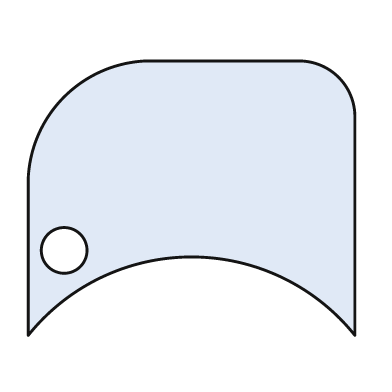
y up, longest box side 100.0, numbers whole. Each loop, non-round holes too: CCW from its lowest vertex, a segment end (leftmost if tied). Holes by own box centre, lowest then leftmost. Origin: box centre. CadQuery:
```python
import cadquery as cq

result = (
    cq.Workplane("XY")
    .moveTo(-50.0, -42.0)
    .threePointArc((0.0, -18.0), (50.0, -42.0))
    .lineTo(50.0, 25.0)
    .threePointArc((45.0, 37.0), (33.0, 42.0))
    .lineTo(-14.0, 42.0)
    .threePointArc((-39.0, 31.0), (-50.0, 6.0))
    .close()
    .moveTo(-39.0, -16.0)
    .circle(7.0)
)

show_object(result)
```